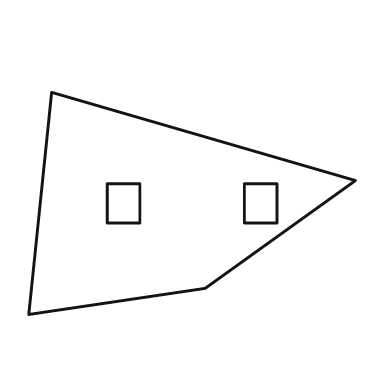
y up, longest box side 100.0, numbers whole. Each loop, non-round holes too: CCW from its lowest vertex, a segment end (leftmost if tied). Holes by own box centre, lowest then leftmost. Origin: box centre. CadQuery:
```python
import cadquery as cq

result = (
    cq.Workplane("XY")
    .moveTo(-50.0, -34.0)
    .lineTo(4.0, -26.0)
    .lineTo(50.0, 7.0)
    .lineTo(-43.0, 34.0)
    .close()
    .moveTo(-26.0, -6.0)
    .lineTo(-16.0, -6.0)
    .lineTo(-16.0, 6.0)
    .lineTo(-26.0, 6.0)
    .close()
    .moveTo(16.0, -6.0)
    .lineTo(26.0, -6.0)
    .lineTo(26.0, 6.0)
    .lineTo(16.0, 6.0)
    .close()
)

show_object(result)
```